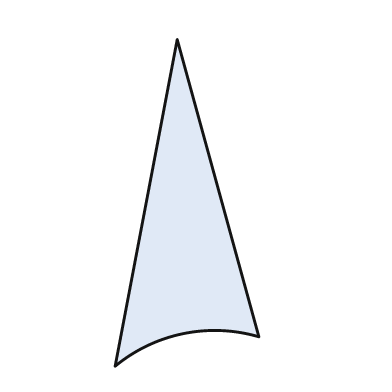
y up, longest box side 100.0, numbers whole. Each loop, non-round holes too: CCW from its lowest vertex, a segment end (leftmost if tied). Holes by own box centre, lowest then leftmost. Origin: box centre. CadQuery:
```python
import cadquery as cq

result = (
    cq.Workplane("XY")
    .moveTo(-22.0, -50.0)
    .threePointArc((-1.0, -40.0), (22.0, -41.0))
    .lineTo(-3.0, 50.0)
    .close()
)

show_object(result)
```